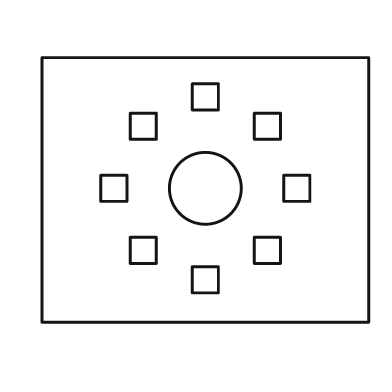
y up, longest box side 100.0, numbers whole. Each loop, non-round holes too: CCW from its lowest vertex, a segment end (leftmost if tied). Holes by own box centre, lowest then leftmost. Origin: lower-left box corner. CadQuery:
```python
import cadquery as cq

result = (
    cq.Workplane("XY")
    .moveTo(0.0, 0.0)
    .lineTo(100.0, 0.0)
    .lineTo(100.0, 81.0)
    .lineTo(0.0, 81.0)
    .close()
    .moveTo(46.0, 9.0)
    .lineTo(54.0, 9.0)
    .lineTo(54.0, 17.0)
    .lineTo(46.0, 17.0)
    .close()
    .moveTo(27.0, 18.0)
    .lineTo(35.0, 18.0)
    .lineTo(35.0, 26.0)
    .lineTo(27.0, 26.0)
    .close()
    .moveTo(65.0, 18.0)
    .lineTo(73.0, 18.0)
    .lineTo(73.0, 26.0)
    .lineTo(65.0, 26.0)
    .close()
    .moveTo(18.0, 37.0)
    .lineTo(26.0, 37.0)
    .lineTo(26.0, 45.0)
    .lineTo(18.0, 45.0)
    .close()
    .moveTo(50.0, 41.0)
    .circle(11.0)
    .moveTo(74.0, 37.0)
    .lineTo(82.0, 37.0)
    .lineTo(82.0, 45.0)
    .lineTo(74.0, 45.0)
    .close()
    .moveTo(27.0, 56.0)
    .lineTo(35.0, 56.0)
    .lineTo(35.0, 64.0)
    .lineTo(27.0, 64.0)
    .close()
    .moveTo(65.0, 56.0)
    .lineTo(73.0, 56.0)
    .lineTo(73.0, 64.0)
    .lineTo(65.0, 64.0)
    .close()
    .moveTo(46.0, 65.0)
    .lineTo(54.0, 65.0)
    .lineTo(54.0, 73.0)
    .lineTo(46.0, 73.0)
    .close()
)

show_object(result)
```